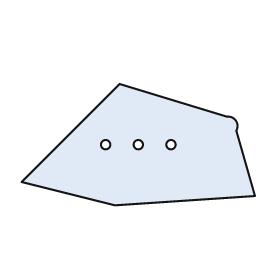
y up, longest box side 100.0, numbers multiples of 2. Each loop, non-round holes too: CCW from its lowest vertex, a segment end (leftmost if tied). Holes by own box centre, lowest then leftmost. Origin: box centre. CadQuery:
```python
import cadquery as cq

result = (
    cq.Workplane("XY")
    .moveTo(-10.0, -26.0)
    .lineTo(50.0, -22.0)
    .lineTo(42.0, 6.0)
    .threePointArc((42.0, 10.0), (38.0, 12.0))
    .lineTo(-8.0, 26.0)
    .lineTo(-50.0, -16.0)
    .close()
    .moveTo(-14.0, 0.0)
    .circle(2.0)
    .moveTo(0.0, 0.0)
    .circle(2.0)
    .moveTo(14.0, 0.0)
    .circle(2.0)
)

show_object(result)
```